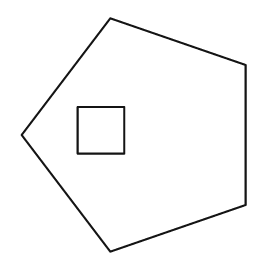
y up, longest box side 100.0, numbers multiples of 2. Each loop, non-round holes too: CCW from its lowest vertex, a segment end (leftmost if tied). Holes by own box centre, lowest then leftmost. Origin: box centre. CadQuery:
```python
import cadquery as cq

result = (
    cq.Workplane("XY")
    .moveTo(-10.0, -50.0)
    .lineTo(48.0, -30.0)
    .lineTo(48.0, 30.0)
    .lineTo(-10.0, 50.0)
    .lineTo(-48.0, 0.0)
    .close()
    .moveTo(-24.0, -8.0)
    .lineTo(-4.0, -8.0)
    .lineTo(-4.0, 12.0)
    .lineTo(-24.0, 12.0)
    .close()
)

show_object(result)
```